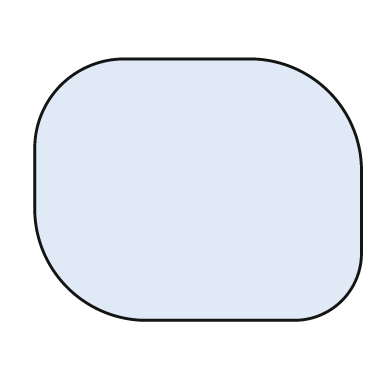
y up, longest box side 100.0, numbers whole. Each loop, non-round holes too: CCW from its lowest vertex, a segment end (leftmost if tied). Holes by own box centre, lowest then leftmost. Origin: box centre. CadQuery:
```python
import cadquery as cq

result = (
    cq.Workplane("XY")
    .moveTo(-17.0, -40.0)
    .lineTo(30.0, -40.0)
    .threePointArc((44.0, -34.0), (50.0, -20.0))
    .lineTo(50.0, 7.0)
    .threePointArc((40.0, 30.0), (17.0, 40.0))
    .lineTo(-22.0, 40.0)
    .threePointArc((-42.0, 32.0), (-50.0, 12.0))
    .lineTo(-50.0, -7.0)
    .threePointArc((-40.0, -30.0), (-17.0, -40.0))
    .close()
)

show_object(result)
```